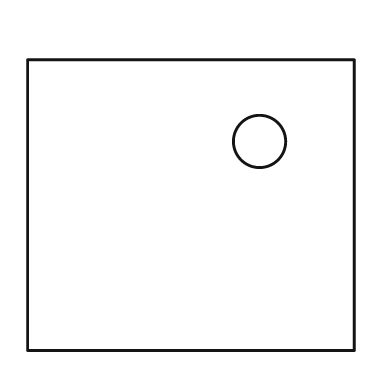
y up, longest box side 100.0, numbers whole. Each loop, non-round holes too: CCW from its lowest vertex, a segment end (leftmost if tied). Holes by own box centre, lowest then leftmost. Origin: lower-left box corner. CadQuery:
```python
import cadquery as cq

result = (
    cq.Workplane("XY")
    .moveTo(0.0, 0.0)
    .lineTo(100.0, 0.0)
    .lineTo(100.0, 89.0)
    .lineTo(0.0, 89.0)
    .close()
    .moveTo(71.0, 64.0)
    .circle(8.0)
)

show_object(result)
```